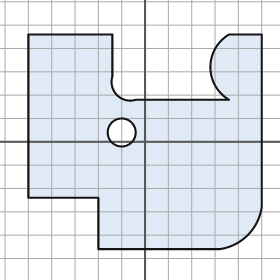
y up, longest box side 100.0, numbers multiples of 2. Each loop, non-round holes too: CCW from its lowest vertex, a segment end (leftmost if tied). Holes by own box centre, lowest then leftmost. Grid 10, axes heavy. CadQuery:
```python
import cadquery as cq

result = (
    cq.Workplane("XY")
    .moveTo(-20.0, -46.0)
    .lineTo(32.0, -46.0)
    .threePointArc((44.0, -40.0), (50.0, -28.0))
    .lineTo(50.0, 46.0)
    .lineTo(36.0, 46.0)
    .threePointArc((28.0, 32.0), (36.0, 18.0))
    .lineTo(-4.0, 18.0)
    .threePointArc((-12.0, 20.0), (-14.0, 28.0))
    .lineTo(-14.0, 46.0)
    .lineTo(-50.0, 46.0)
    .lineTo(-50.0, -24.0)
    .lineTo(-20.0, -24.0)
    .close()
    .moveTo(-10.0, 4.0)
    .circle(6.0)
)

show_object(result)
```